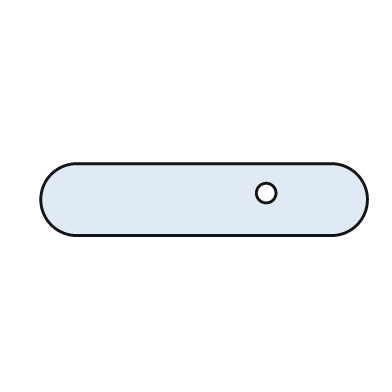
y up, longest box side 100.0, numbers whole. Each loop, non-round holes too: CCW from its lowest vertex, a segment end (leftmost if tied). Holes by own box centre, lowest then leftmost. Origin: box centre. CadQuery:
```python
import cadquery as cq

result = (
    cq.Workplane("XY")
    .moveTo(-39.0, -11.0)
    .lineTo(39.0, -11.0)
    .threePointArc((50.0, 0.0), (39.0, 11.0))
    .lineTo(-39.0, 11.0)
    .threePointArc((-50.0, 0.0), (-39.0, -11.0))
    .close()
    .moveTo(19.0, 2.0)
    .circle(3.0)
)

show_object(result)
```